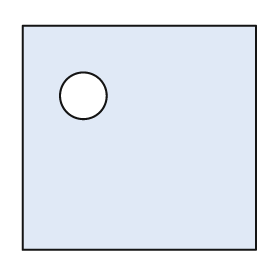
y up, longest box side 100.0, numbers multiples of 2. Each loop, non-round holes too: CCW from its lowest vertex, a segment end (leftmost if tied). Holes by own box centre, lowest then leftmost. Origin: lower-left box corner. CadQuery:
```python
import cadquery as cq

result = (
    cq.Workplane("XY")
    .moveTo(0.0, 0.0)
    .lineTo(100.0, 0.0)
    .lineTo(100.0, 96.0)
    .lineTo(0.0, 96.0)
    .close()
    .moveTo(26.0, 66.0)
    .circle(10.0)
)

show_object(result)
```